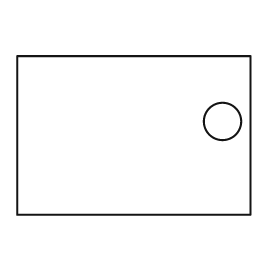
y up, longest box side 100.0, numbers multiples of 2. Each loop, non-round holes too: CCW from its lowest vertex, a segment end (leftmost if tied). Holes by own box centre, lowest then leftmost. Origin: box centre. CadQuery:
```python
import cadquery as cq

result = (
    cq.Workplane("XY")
    .moveTo(-50.0, -34.0)
    .lineTo(50.0, -34.0)
    .lineTo(50.0, 34.0)
    .lineTo(-50.0, 34.0)
    .close()
    .moveTo(38.0, 6.0)
    .circle(8.0)
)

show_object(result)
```